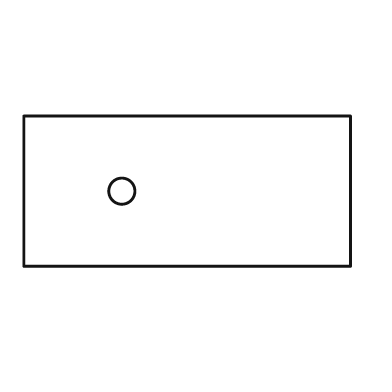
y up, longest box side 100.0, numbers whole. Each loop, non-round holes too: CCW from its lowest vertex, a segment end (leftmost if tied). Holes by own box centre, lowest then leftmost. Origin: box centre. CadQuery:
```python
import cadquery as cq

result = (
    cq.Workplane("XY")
    .moveTo(-50.0, -23.0)
    .lineTo(50.0, -23.0)
    .lineTo(50.0, 23.0)
    .lineTo(-50.0, 23.0)
    .close()
    .moveTo(-20.0, 0.0)
    .circle(4.0)
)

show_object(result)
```